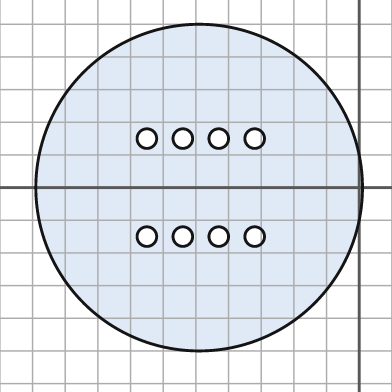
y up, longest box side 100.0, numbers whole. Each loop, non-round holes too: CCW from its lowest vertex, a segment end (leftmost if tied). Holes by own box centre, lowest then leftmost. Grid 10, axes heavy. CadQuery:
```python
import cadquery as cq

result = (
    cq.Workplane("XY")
    .moveTo(-49.0, 0.0)
    .circle(50.0)
    .moveTo(-65.0, -15.0)
    .circle(3.0)
    .moveTo(-54.0, -15.0)
    .circle(3.0)
    .moveTo(-43.0, -15.0)
    .circle(3.0)
    .moveTo(-32.0, -15.0)
    .circle(3.0)
    .moveTo(-65.0, 15.0)
    .circle(3.0)
    .moveTo(-54.0, 15.0)
    .circle(3.0)
    .moveTo(-43.0, 15.0)
    .circle(3.0)
    .moveTo(-32.0, 15.0)
    .circle(3.0)
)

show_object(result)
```